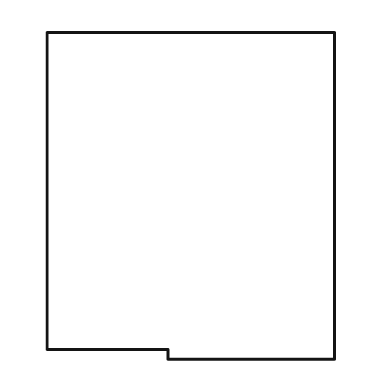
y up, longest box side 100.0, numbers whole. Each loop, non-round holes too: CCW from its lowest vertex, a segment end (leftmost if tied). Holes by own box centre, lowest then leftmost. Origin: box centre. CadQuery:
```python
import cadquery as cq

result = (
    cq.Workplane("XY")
    .moveTo(-7.0, -50.0)
    .lineTo(44.0, -50.0)
    .lineTo(44.0, 50.0)
    .lineTo(-44.0, 50.0)
    .lineTo(-44.0, -47.0)
    .lineTo(-7.0, -47.0)
    .close()
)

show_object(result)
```